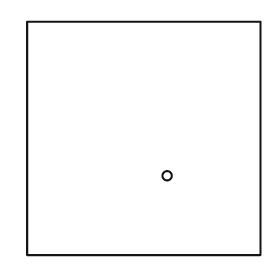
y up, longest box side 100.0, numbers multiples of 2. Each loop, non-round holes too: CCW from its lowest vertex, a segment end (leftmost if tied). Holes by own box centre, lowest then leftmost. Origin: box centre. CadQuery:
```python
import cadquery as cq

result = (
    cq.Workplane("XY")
    .moveTo(-50.0, -50.0)
    .lineTo(50.0, -50.0)
    .lineTo(50.0, 50.0)
    .lineTo(-50.0, 50.0)
    .close()
    .moveTo(10.0, -16.0)
    .circle(2.0)
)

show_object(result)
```